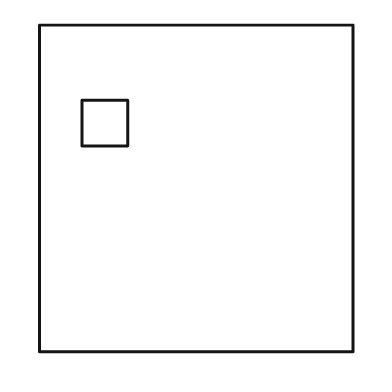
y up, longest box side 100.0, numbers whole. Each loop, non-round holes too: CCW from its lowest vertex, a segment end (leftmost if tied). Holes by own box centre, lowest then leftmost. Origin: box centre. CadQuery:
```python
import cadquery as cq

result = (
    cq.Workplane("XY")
    .moveTo(-48.0, -50.0)
    .lineTo(48.0, -50.0)
    .lineTo(48.0, 50.0)
    .lineTo(-48.0, 50.0)
    .close()
    .moveTo(-35.0, 13.0)
    .lineTo(-21.0, 13.0)
    .lineTo(-21.0, 27.0)
    .lineTo(-35.0, 27.0)
    .close()
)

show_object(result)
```